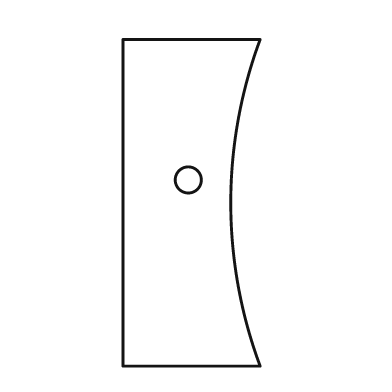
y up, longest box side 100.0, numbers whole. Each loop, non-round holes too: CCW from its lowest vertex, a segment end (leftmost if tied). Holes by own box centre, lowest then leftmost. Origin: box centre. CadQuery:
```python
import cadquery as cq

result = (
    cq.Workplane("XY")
    .moveTo(-21.0, -50.0)
    .lineTo(21.0, -50.0)
    .threePointArc((12.0, 0.0), (21.0, 50.0))
    .lineTo(-21.0, 50.0)
    .close()
    .moveTo(-1.0, 7.0)
    .circle(4.0)
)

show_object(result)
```